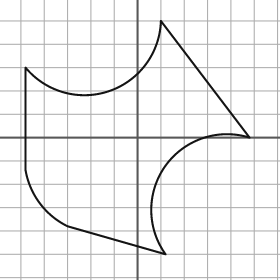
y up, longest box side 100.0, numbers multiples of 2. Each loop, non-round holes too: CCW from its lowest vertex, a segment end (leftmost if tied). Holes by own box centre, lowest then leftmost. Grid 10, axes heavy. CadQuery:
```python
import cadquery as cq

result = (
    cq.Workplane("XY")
    .moveTo(12.0, -50.0)
    .threePointArc((12.0, -12.0), (48.0, 0.0))
    .lineTo(10.0, 50.0)
    .threePointArc((-12.0, 20.0), (-48.0, 30.0))
    .lineTo(-48.0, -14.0)
    .threePointArc((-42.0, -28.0), (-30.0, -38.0))
    .close()
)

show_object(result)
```